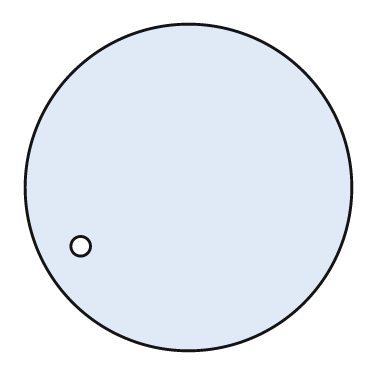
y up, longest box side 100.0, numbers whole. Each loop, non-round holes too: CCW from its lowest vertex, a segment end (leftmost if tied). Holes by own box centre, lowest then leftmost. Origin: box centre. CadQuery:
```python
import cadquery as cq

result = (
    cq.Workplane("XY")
    .moveTo(0.0, 0.0)
    .circle(50.0)
    .moveTo(-33.0, -18.0)
    .circle(3.0)
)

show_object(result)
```